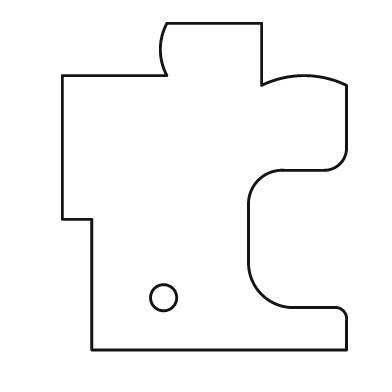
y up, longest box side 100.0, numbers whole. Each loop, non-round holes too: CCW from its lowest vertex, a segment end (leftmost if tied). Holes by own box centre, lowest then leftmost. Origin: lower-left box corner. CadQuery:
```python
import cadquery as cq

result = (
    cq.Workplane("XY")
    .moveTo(9.0, 0.0)
    .lineTo(87.0, 0.0)
    .lineTo(87.0, 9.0)
    .threePointArc((86.0, 12.0), (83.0, 13.0))
    .lineTo(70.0, 13.0)
    .threePointArc((61.0, 17.0), (57.0, 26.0))
    .lineTo(57.0, 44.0)
    .threePointArc((60.0, 52.0), (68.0, 55.0))
    .lineTo(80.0, 55.0)
    .threePointArc((85.0, 57.0), (87.0, 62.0))
    .lineTo(87.0, 81.0)
    .threePointArc((74.0, 84.0), (61.0, 81.0))
    .lineTo(61.0, 100.0)
    .lineTo(32.0, 100.0)
    .threePointArc((30.0, 92.0), (32.0, 84.0))
    .lineTo(0.0, 84.0)
    .lineTo(0.0, 40.0)
    .lineTo(9.0, 40.0)
    .close()
    .moveTo(31.0, 16.0)
    .circle(4.0)
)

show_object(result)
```